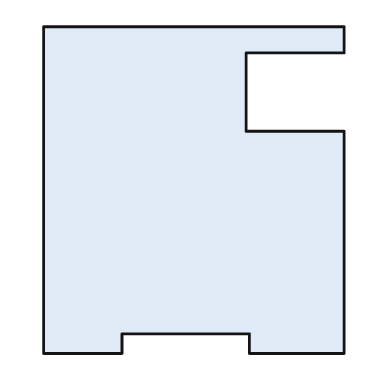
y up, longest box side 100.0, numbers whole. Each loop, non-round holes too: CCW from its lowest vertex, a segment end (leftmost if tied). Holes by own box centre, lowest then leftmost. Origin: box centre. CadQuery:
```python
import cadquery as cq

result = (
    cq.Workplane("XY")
    .moveTo(-46.0, -50.0)
    .lineTo(-22.0, -50.0)
    .lineTo(-22.0, -44.0)
    .lineTo(17.0, -44.0)
    .lineTo(17.0, -50.0)
    .lineTo(46.0, -50.0)
    .lineTo(46.0, 18.0)
    .lineTo(16.0, 18.0)
    .lineTo(16.0, 42.0)
    .lineTo(46.0, 42.0)
    .lineTo(46.0, 50.0)
    .lineTo(-46.0, 50.0)
    .close()
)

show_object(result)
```